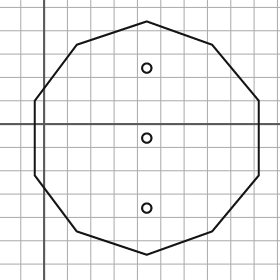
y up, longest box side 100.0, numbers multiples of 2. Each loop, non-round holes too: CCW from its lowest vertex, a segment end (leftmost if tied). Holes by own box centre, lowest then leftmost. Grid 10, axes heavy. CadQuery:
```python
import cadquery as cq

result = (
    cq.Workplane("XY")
    .moveTo(44.0, -56.0)
    .lineTo(72.0, -46.0)
    .lineTo(92.0, -22.0)
    .lineTo(92.0, 10.0)
    .lineTo(72.0, 34.0)
    .lineTo(44.0, 44.0)
    .lineTo(14.0, 34.0)
    .lineTo(-4.0, 10.0)
    .lineTo(-4.0, -22.0)
    .lineTo(14.0, -46.0)
    .close()
    .moveTo(44.0, -36.0)
    .circle(2.0)
    .moveTo(44.0, -6.0)
    .circle(2.0)
    .moveTo(44.0, 24.0)
    .circle(2.0)
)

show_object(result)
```